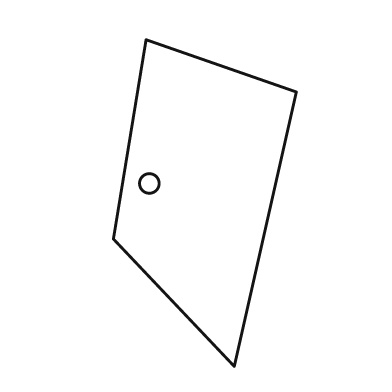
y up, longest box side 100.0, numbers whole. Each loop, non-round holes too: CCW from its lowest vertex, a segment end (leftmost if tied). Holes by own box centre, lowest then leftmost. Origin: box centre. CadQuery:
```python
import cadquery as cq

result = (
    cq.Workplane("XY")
    .moveTo(9.0, -50.0)
    .lineTo(28.0, 34.0)
    .lineTo(-18.0, 50.0)
    .lineTo(-28.0, -11.0)
    .close()
    .moveTo(-17.0, 6.0)
    .circle(3.0)
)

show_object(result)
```